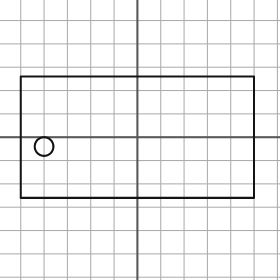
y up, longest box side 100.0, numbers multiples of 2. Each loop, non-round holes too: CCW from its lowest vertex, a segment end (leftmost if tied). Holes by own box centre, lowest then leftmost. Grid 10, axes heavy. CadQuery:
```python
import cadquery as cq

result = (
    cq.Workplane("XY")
    .moveTo(-50.0, -26.0)
    .lineTo(50.0, -26.0)
    .lineTo(50.0, 26.0)
    .lineTo(-50.0, 26.0)
    .close()
    .moveTo(-40.0, -4.0)
    .circle(4.0)
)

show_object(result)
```